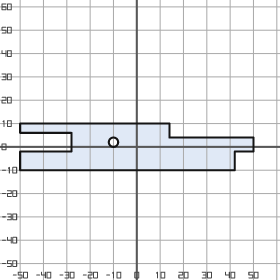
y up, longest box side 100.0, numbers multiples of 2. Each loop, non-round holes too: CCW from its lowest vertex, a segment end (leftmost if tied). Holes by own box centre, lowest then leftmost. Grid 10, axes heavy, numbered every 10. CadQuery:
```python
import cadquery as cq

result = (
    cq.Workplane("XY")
    .moveTo(-50.0, -10.0)
    .lineTo(42.0, -10.0)
    .lineTo(42.0, -2.0)
    .lineTo(50.0, -2.0)
    .lineTo(50.0, 4.0)
    .lineTo(14.0, 4.0)
    .lineTo(14.0, 10.0)
    .lineTo(-50.0, 10.0)
    .lineTo(-50.0, 6.0)
    .lineTo(-28.0, 6.0)
    .lineTo(-28.0, -2.0)
    .lineTo(-50.0, -2.0)
    .close()
    .moveTo(-10.0, 2.0)
    .circle(2.0)
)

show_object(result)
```